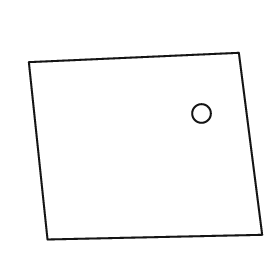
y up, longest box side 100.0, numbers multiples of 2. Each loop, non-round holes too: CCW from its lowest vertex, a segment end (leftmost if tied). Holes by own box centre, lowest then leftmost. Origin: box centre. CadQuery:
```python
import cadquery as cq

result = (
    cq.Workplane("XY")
    .moveTo(-42.0, -40.0)
    .lineTo(50.0, -38.0)
    .lineTo(40.0, 40.0)
    .lineTo(-50.0, 36.0)
    .close()
    .moveTo(24.0, 14.0)
    .circle(4.0)
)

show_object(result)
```